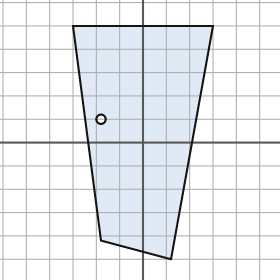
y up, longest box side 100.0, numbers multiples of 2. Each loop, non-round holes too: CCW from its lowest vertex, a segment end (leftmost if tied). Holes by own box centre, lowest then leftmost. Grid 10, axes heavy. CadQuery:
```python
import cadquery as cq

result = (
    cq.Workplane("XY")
    .moveTo(12.0, -50.0)
    .lineTo(30.0, 50.0)
    .lineTo(-30.0, 50.0)
    .lineTo(-18.0, -42.0)
    .close()
    .moveTo(-18.0, 10.0)
    .circle(2.0)
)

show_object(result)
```